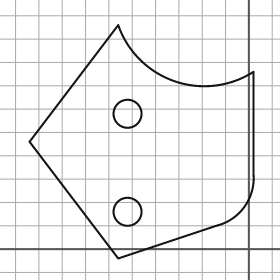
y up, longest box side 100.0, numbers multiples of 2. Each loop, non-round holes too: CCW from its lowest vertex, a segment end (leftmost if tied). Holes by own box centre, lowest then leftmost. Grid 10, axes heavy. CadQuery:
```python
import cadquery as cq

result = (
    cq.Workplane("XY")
    .moveTo(-56.0, -4.0)
    .lineTo(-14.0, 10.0)
    .threePointArc((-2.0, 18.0), (2.0, 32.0))
    .lineTo(2.0, 76.0)
    .threePointArc((-32.0, 72.0), (-56.0, 96.0))
    .lineTo(-94.0, 46.0)
    .close()
    .moveTo(-52.0, 16.0)
    .circle(6.0)
    .moveTo(-52.0, 58.0)
    .circle(6.0)
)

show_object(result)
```